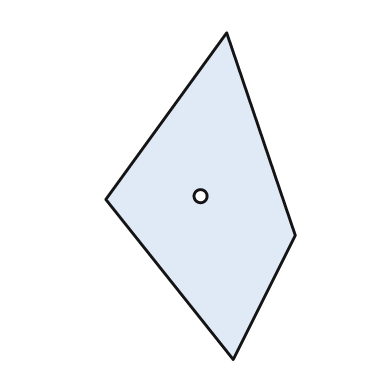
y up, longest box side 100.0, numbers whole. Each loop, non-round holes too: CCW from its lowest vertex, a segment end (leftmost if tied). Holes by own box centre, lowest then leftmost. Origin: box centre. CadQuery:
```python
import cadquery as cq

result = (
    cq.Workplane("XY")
    .moveTo(10.0, -50.0)
    .lineTo(29.0, -12.0)
    .lineTo(8.0, 50.0)
    .lineTo(-29.0, -1.0)
    .close()
    .moveTo(0.0, 0.0)
    .circle(2.0)
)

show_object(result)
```